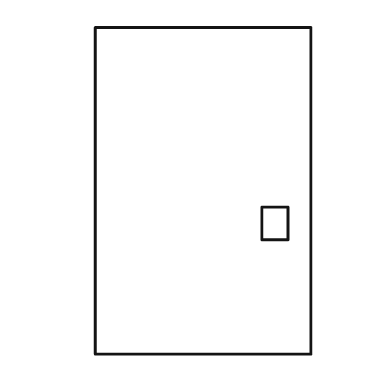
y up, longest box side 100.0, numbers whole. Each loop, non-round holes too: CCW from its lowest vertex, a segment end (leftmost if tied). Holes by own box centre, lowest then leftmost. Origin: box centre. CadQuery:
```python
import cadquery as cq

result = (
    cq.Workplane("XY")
    .moveTo(-33.0, -50.0)
    .lineTo(33.0, -50.0)
    .lineTo(33.0, 50.0)
    .lineTo(-33.0, 50.0)
    .close()
    .moveTo(18.0, -15.0)
    .lineTo(26.0, -15.0)
    .lineTo(26.0, -5.0)
    .lineTo(18.0, -5.0)
    .close()
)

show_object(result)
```